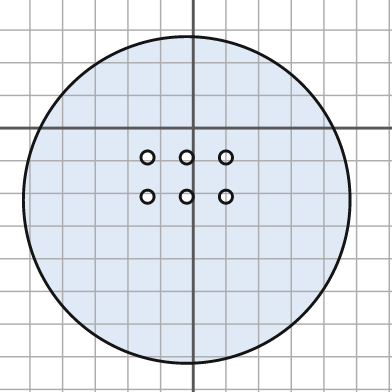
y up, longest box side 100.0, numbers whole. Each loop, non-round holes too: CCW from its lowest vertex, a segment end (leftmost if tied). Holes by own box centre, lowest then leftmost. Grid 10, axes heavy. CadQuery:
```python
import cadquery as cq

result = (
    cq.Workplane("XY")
    .moveTo(-2.0, -22.0)
    .circle(50.0)
    .moveTo(-14.0, -21.0)
    .circle(2.0)
    .moveTo(-2.0, -21.0)
    .circle(2.0)
    .moveTo(10.0, -21.0)
    .circle(2.0)
    .moveTo(-14.0, -9.0)
    .circle(2.0)
    .moveTo(-2.0, -9.0)
    .circle(2.0)
    .moveTo(10.0, -9.0)
    .circle(2.0)
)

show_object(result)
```